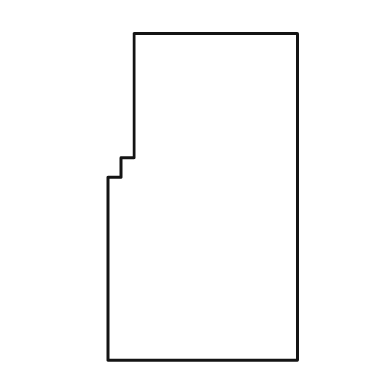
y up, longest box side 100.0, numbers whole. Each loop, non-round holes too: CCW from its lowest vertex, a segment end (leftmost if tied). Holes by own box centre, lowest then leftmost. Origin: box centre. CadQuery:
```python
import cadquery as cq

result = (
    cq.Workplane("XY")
    .moveTo(-29.0, -50.0)
    .lineTo(29.0, -50.0)
    .lineTo(29.0, 50.0)
    .lineTo(-21.0, 50.0)
    .lineTo(-21.0, 12.0)
    .lineTo(-25.0, 12.0)
    .lineTo(-25.0, 6.0)
    .lineTo(-29.0, 6.0)
    .close()
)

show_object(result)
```